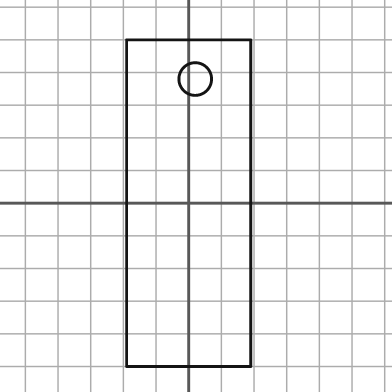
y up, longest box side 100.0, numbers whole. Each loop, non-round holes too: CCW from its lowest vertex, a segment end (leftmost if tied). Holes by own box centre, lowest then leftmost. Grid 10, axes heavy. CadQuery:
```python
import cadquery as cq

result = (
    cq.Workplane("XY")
    .moveTo(-19.0, -50.0)
    .lineTo(19.0, -50.0)
    .lineTo(19.0, 50.0)
    .lineTo(-19.0, 50.0)
    .close()
    .moveTo(2.0, 38.0)
    .circle(5.0)
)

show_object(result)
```